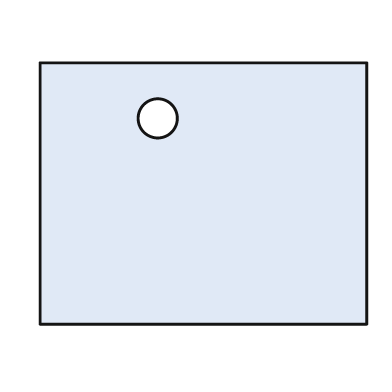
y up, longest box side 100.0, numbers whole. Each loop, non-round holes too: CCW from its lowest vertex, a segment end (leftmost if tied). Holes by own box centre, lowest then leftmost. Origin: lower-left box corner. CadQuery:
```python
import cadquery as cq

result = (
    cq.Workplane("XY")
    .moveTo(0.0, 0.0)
    .lineTo(100.0, 0.0)
    .lineTo(100.0, 80.0)
    .lineTo(0.0, 80.0)
    .close()
    .moveTo(36.0, 63.0)
    .circle(6.0)
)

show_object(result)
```